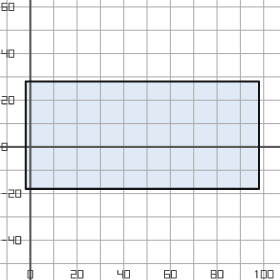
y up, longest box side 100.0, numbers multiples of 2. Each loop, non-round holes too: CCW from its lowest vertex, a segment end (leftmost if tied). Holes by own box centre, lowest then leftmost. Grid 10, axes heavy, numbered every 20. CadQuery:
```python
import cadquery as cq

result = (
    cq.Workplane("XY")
    .moveTo(-2.0, -18.0)
    .lineTo(98.0, -18.0)
    .lineTo(98.0, 28.0)
    .lineTo(-2.0, 28.0)
    .close()
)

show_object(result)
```